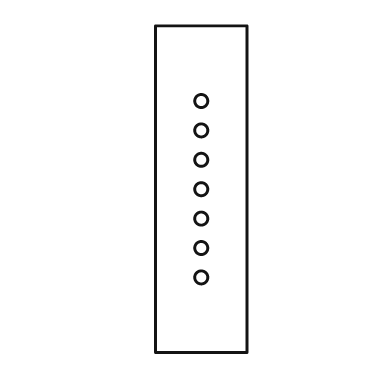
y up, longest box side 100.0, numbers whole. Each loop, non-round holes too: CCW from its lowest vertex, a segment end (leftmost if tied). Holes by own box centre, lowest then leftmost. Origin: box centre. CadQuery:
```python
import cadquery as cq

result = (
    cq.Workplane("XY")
    .moveTo(-14.0, -50.0)
    .lineTo(14.0, -50.0)
    .lineTo(14.0, 50.0)
    .lineTo(-14.0, 50.0)
    .close()
    .moveTo(0.0, -27.0)
    .circle(2.0)
    .moveTo(0.0, -18.0)
    .circle(2.0)
    .moveTo(0.0, -9.0)
    .circle(2.0)
    .moveTo(0.0, 0.0)
    .circle(2.0)
    .moveTo(0.0, 9.0)
    .circle(2.0)
    .moveTo(0.0, 18.0)
    .circle(2.0)
    .moveTo(0.0, 27.0)
    .circle(2.0)
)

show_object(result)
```